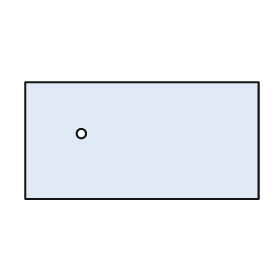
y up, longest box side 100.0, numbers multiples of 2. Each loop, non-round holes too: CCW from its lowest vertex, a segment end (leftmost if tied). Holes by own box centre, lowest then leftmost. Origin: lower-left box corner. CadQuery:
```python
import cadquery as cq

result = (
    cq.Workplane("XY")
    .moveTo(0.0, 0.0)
    .lineTo(100.0, 0.0)
    .lineTo(100.0, 50.0)
    .lineTo(0.0, 50.0)
    .close()
    .moveTo(24.0, 28.0)
    .circle(2.0)
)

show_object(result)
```